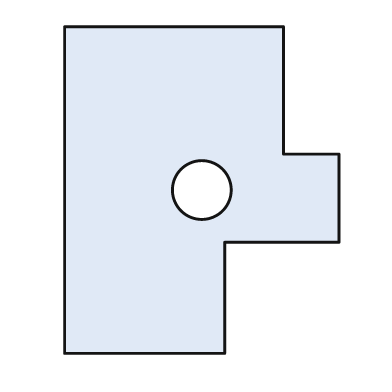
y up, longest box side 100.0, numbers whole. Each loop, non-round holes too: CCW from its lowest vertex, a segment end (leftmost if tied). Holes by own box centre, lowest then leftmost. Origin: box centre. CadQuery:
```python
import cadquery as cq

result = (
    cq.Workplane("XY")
    .moveTo(-42.0, -50.0)
    .lineTo(7.0, -50.0)
    .lineTo(7.0, -16.0)
    .lineTo(42.0, -16.0)
    .lineTo(42.0, 11.0)
    .lineTo(25.0, 11.0)
    .lineTo(25.0, 50.0)
    .lineTo(-42.0, 50.0)
    .close()
    .moveTo(0.0, 0.0)
    .circle(9.0)
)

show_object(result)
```